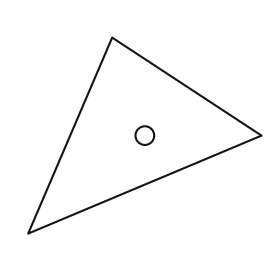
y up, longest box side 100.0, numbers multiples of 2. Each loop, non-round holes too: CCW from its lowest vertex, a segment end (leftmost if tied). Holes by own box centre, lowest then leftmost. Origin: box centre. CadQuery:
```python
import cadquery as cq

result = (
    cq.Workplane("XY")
    .moveTo(-50.0, -42.0)
    .lineTo(50.0, 0.0)
    .lineTo(-14.0, 42.0)
    .close()
    .moveTo(0.0, 0.0)
    .circle(4.0)
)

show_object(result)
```